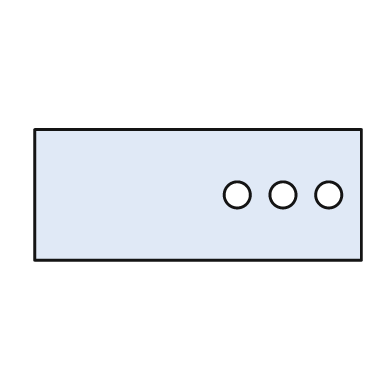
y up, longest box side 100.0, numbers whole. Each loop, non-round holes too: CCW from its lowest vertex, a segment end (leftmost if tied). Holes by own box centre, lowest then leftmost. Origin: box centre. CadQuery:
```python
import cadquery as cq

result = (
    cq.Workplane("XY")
    .moveTo(-50.0, -20.0)
    .lineTo(50.0, -20.0)
    .lineTo(50.0, 20.0)
    .lineTo(-50.0, 20.0)
    .close()
    .moveTo(12.0, 0.0)
    .circle(4.0)
    .moveTo(26.0, 0.0)
    .circle(4.0)
    .moveTo(40.0, 0.0)
    .circle(4.0)
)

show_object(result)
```